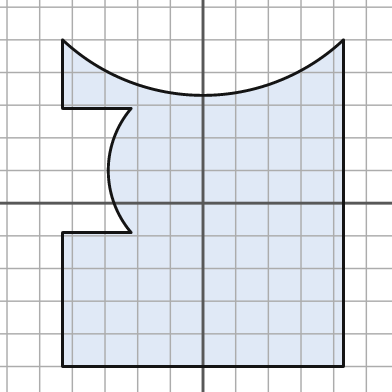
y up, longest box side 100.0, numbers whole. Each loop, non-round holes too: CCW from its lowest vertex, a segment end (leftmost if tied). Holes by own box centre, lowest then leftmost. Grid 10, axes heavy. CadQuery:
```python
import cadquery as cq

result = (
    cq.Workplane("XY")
    .moveTo(-43.0, -50.0)
    .lineTo(43.0, -50.0)
    .lineTo(43.0, 50.0)
    .threePointArc((0.0, 33.0), (-43.0, 50.0))
    .lineTo(-43.0, 29.0)
    .lineTo(-22.0, 29.0)
    .threePointArc((-29.0, 10.0), (-22.0, -9.0))
    .lineTo(-43.0, -9.0)
    .close()
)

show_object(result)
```